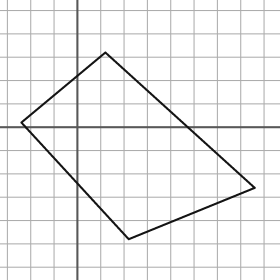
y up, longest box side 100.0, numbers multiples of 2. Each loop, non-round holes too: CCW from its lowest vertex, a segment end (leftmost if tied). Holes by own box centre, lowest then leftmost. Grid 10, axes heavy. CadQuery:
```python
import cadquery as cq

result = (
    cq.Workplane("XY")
    .moveTo(22.0, -48.0)
    .lineTo(76.0, -26.0)
    .lineTo(12.0, 32.0)
    .lineTo(-24.0, 2.0)
    .close()
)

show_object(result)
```